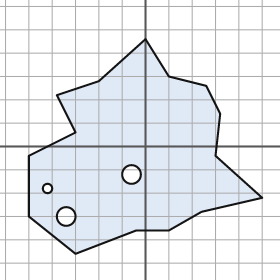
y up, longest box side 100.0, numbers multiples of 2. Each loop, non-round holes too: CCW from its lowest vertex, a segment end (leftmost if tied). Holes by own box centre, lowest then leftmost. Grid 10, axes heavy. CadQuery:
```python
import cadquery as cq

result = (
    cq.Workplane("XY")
    .moveTo(-30.0, -46.0)
    .lineTo(-4.0, -36.0)
    .lineTo(10.0, -36.0)
    .lineTo(24.0, -28.0)
    .lineTo(50.0, -22.0)
    .lineTo(30.0, -4.0)
    .lineTo(32.0, 14.0)
    .lineTo(26.0, 26.0)
    .lineTo(10.0, 30.0)
    .lineTo(0.0, 46.0)
    .lineTo(-20.0, 28.0)
    .lineTo(-38.0, 22.0)
    .lineTo(-30.0, 6.0)
    .lineTo(-50.0, -4.0)
    .lineTo(-50.0, -30.0)
    .close()
    .moveTo(-34.0, -30.0)
    .circle(4.0)
    .moveTo(-42.0, -18.0)
    .circle(2.0)
    .moveTo(-6.0, -12.0)
    .circle(4.0)
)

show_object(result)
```